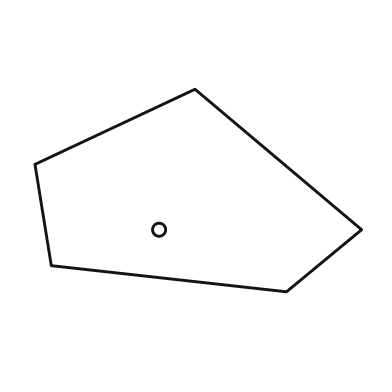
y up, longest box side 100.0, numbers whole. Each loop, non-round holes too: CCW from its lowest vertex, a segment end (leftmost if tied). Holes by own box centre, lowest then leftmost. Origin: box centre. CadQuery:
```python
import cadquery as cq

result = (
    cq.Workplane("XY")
    .moveTo(27.0, -31.0)
    .lineTo(50.0, -12.0)
    .lineTo(-1.0, 31.0)
    .lineTo(-50.0, 8.0)
    .lineTo(-45.0, -23.0)
    .close()
    .moveTo(-12.0, -12.0)
    .circle(2.0)
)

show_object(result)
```